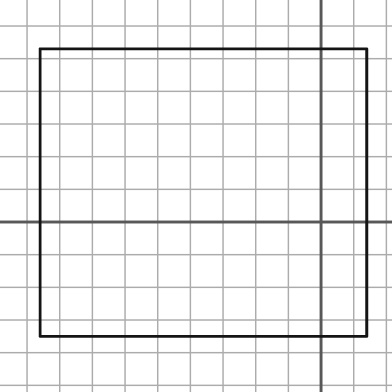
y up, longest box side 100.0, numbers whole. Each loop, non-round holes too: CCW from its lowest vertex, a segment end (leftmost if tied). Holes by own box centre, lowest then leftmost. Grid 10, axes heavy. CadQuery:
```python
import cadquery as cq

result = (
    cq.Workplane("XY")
    .moveTo(-86.0, -35.0)
    .lineTo(14.0, -35.0)
    .lineTo(14.0, 53.0)
    .lineTo(-86.0, 53.0)
    .close()
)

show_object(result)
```